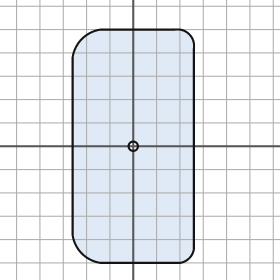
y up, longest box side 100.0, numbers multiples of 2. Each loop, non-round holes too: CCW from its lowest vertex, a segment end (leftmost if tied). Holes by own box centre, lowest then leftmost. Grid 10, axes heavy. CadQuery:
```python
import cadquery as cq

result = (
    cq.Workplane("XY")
    .moveTo(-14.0, -50.0)
    .lineTo(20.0, -50.0)
    .threePointArc((24.0, -48.0), (26.0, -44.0))
    .lineTo(26.0, 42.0)
    .threePointArc((24.0, 48.0), (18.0, 50.0))
    .lineTo(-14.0, 50.0)
    .threePointArc((-22.0, 46.0), (-26.0, 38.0))
    .lineTo(-26.0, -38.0)
    .threePointArc((-22.0, -46.0), (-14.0, -50.0))
    .close()
    .moveTo(0.0, 0.0)
    .circle(2.0)
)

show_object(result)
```